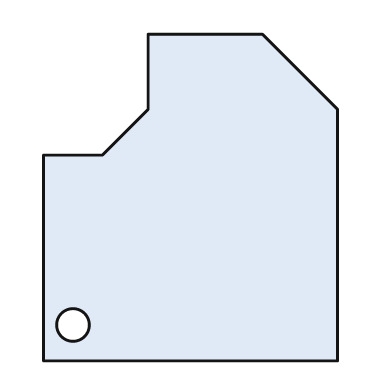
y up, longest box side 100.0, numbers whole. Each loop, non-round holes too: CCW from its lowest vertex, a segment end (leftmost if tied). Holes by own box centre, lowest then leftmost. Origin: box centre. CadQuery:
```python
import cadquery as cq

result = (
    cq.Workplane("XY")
    .moveTo(-45.0, -50.0)
    .lineTo(45.0, -50.0)
    .lineTo(45.0, 27.0)
    .lineTo(22.0, 50.0)
    .lineTo(-13.0, 50.0)
    .lineTo(-13.0, 27.0)
    .lineTo(-27.0, 13.0)
    .lineTo(-45.0, 13.0)
    .close()
    .moveTo(-36.0, -39.0)
    .circle(5.0)
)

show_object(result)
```